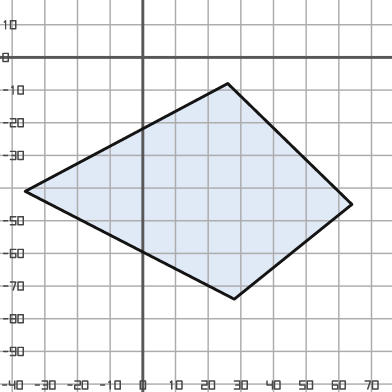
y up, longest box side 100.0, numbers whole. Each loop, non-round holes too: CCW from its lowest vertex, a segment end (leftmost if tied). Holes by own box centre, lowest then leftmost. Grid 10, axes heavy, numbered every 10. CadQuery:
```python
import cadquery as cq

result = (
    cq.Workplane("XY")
    .moveTo(28.0, -74.0)
    .lineTo(64.0, -45.0)
    .lineTo(26.0, -8.0)
    .lineTo(-36.0, -41.0)
    .close()
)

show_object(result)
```